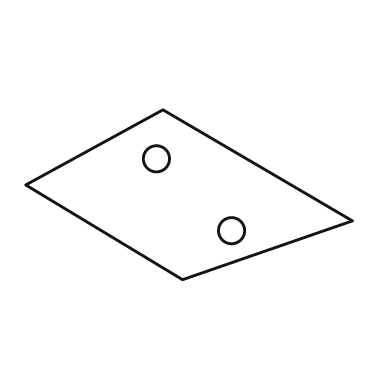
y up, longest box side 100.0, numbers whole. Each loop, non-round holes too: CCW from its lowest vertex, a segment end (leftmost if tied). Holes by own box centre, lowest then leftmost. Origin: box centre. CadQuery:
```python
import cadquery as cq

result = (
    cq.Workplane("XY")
    .moveTo(-2.0, -26.0)
    .lineTo(50.0, -8.0)
    .lineTo(-8.0, 26.0)
    .lineTo(-50.0, 3.0)
    .close()
    .moveTo(13.0, -11.0)
    .circle(4.0)
    .moveTo(-10.0, 11.0)
    .circle(4.0)
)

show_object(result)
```